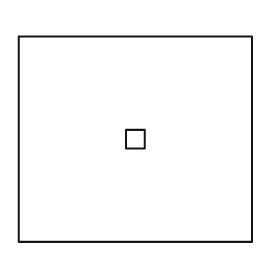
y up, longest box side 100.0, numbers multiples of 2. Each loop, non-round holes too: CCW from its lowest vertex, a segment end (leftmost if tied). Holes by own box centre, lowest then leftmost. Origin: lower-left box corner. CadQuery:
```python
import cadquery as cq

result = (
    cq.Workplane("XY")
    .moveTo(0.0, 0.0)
    .lineTo(100.0, 0.0)
    .lineTo(100.0, 88.0)
    .lineTo(0.0, 88.0)
    .close()
    .moveTo(46.0, 40.0)
    .lineTo(54.0, 40.0)
    .lineTo(54.0, 48.0)
    .lineTo(46.0, 48.0)
    .close()
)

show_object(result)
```